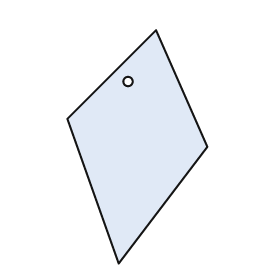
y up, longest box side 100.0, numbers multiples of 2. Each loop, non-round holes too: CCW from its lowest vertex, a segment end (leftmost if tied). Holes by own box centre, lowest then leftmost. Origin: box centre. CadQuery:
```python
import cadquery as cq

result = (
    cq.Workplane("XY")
    .moveTo(-8.0, -50.0)
    .lineTo(30.0, 0.0)
    .lineTo(8.0, 50.0)
    .lineTo(-30.0, 12.0)
    .close()
    .moveTo(-4.0, 28.0)
    .circle(2.0)
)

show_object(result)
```